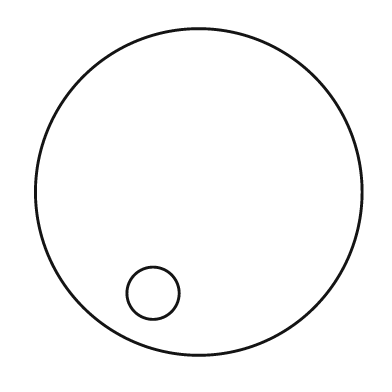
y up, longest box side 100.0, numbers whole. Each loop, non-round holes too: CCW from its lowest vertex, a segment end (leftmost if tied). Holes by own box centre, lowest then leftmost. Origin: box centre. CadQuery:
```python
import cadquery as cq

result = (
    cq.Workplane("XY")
    .moveTo(0.0, 0.0)
    .circle(50.0)
    .moveTo(-14.0, -31.0)
    .circle(8.0)
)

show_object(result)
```